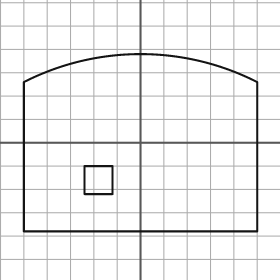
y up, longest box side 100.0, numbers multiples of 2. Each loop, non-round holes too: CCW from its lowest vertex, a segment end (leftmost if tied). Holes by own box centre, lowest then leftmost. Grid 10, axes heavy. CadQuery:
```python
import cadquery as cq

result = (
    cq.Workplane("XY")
    .moveTo(-50.0, -38.0)
    .lineTo(50.0, -38.0)
    .lineTo(50.0, 26.0)
    .threePointArc((0.0, 38.0), (-50.0, 26.0))
    .close()
    .moveTo(-24.0, -22.0)
    .lineTo(-12.0, -22.0)
    .lineTo(-12.0, -10.0)
    .lineTo(-24.0, -10.0)
    .close()
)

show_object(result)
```